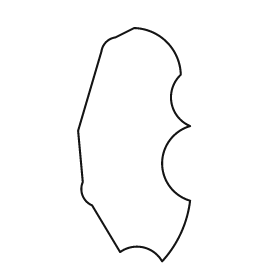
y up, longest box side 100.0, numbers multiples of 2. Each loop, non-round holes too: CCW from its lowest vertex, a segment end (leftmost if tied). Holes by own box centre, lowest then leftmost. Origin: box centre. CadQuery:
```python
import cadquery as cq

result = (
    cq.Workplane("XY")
    .moveTo(12.0, -50.0)
    .threePointArc((20.0, -38.0), (24.0, -24.0))
    .threePointArc((12.0, -8.0), (24.0, 8.0))
    .threePointArc((16.0, 18.0), (20.0, 30.0))
    .threePointArc((14.0, 44.0), (0.0, 50.0))
    .lineTo(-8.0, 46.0)
    .threePointArc((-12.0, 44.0), (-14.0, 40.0))
    .lineTo(-24.0, 6.0)
    .lineTo(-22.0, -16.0)
    .threePointArc((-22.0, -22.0), (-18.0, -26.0))
    .lineTo(-6.0, -46.0)
    .threePointArc((4.0, -44.0), (12.0, -50.0))
    .close()
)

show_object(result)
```